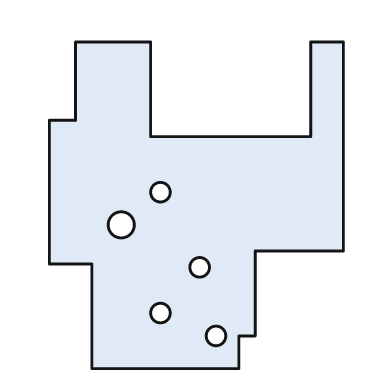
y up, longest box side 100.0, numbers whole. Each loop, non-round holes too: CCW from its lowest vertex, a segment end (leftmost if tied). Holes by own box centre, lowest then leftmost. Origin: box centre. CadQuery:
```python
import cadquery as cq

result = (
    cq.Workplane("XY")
    .moveTo(-32.0, -50.0)
    .lineTo(13.0, -50.0)
    .lineTo(13.0, -40.0)
    .lineTo(18.0, -40.0)
    .lineTo(18.0, -14.0)
    .lineTo(45.0, -14.0)
    .lineTo(45.0, 50.0)
    .lineTo(35.0, 50.0)
    .lineTo(35.0, 21.0)
    .lineTo(-14.0, 21.0)
    .lineTo(-14.0, 50.0)
    .lineTo(-37.0, 50.0)
    .lineTo(-37.0, 26.0)
    .lineTo(-45.0, 26.0)
    .lineTo(-45.0, -18.0)
    .lineTo(-32.0, -18.0)
    .close()
    .moveTo(6.0, -40.0)
    .circle(3.0)
    .moveTo(-11.0, -33.0)
    .circle(3.0)
    .moveTo(1.0, -19.0)
    .circle(3.0)
    .moveTo(-23.0, -6.0)
    .circle(4.0)
    .moveTo(-11.0, 4.0)
    .circle(3.0)
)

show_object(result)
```